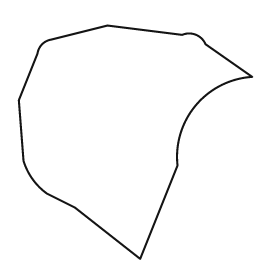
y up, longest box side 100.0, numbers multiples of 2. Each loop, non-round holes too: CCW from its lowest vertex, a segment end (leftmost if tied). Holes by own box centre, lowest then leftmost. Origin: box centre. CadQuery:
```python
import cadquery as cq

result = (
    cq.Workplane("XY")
    .moveTo(2.0, -50.0)
    .lineTo(18.0, -10.0)
    .threePointArc((26.0, 16.0), (50.0, 28.0))
    .lineTo(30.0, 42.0)
    .threePointArc((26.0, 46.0), (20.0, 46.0))
    .lineTo(-12.0, 50.0)
    .lineTo(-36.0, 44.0)
    .threePointArc((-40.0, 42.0), (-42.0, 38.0))
    .lineTo(-50.0, 18.0)
    .lineTo(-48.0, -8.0)
    .threePointArc((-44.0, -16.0), (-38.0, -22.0))
    .lineTo(-26.0, -28.0)
    .close()
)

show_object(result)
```